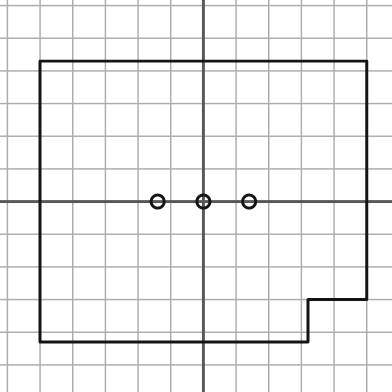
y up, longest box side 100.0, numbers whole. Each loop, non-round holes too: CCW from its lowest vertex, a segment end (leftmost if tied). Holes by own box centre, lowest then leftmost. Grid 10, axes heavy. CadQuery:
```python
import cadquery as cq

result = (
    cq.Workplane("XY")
    .moveTo(-50.0, -43.0)
    .lineTo(32.0, -43.0)
    .lineTo(32.0, -30.0)
    .lineTo(50.0, -30.0)
    .lineTo(50.0, 43.0)
    .lineTo(-50.0, 43.0)
    .close()
    .moveTo(-14.0, 0.0)
    .circle(2.0)
    .moveTo(0.0, 0.0)
    .circle(2.0)
    .moveTo(14.0, 0.0)
    .circle(2.0)
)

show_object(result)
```